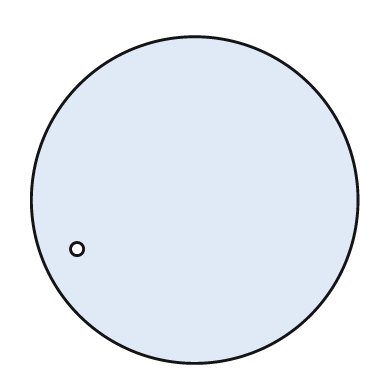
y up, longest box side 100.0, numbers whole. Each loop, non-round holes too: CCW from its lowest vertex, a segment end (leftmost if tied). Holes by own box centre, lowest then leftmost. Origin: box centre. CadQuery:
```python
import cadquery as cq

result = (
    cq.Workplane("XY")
    .moveTo(0.0, 0.0)
    .circle(50.0)
    .moveTo(-36.0, -15.0)
    .circle(2.0)
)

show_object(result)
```